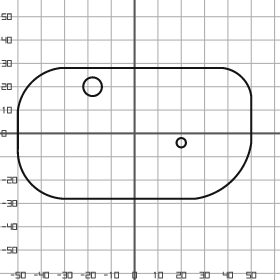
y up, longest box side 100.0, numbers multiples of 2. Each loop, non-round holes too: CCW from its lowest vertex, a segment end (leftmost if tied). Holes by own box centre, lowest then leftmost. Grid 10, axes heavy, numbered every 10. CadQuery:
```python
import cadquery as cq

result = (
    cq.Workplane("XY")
    .moveTo(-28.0, -28.0)
    .lineTo(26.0, -28.0)
    .threePointArc((42.0, -20.0), (50.0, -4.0))
    .lineTo(50.0, 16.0)
    .threePointArc((46.0, 24.0), (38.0, 28.0))
    .lineTo(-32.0, 28.0)
    .threePointArc((-44.0, 22.0), (-50.0, 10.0))
    .lineTo(-50.0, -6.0)
    .threePointArc((-44.0, -22.0), (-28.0, -28.0))
    .close()
    .moveTo(20.0, -4.0)
    .circle(2.0)
    .moveTo(-18.0, 20.0)
    .circle(4.0)
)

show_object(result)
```